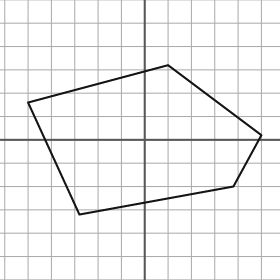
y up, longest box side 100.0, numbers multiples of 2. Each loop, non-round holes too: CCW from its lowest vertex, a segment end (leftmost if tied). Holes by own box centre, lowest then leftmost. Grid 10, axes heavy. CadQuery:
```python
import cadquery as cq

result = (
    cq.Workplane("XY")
    .moveTo(-28.0, -32.0)
    .lineTo(38.0, -20.0)
    .lineTo(50.0, 2.0)
    .lineTo(10.0, 32.0)
    .lineTo(-50.0, 16.0)
    .close()
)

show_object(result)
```